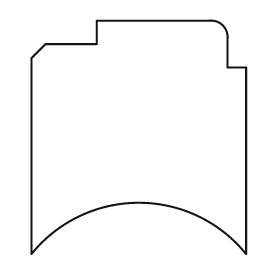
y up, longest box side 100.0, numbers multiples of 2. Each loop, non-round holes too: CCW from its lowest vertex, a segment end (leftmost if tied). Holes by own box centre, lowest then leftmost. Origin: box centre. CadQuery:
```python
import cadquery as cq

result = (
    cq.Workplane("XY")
    .moveTo(-46.0, -50.0)
    .threePointArc((0.0, -28.0), (46.0, -50.0))
    .lineTo(46.0, 30.0)
    .lineTo(38.0, 30.0)
    .lineTo(38.0, 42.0)
    .threePointArc((36.0, 48.0), (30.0, 50.0))
    .lineTo(-18.0, 50.0)
    .lineTo(-18.0, 40.0)
    .lineTo(-40.0, 40.0)
    .lineTo(-46.0, 34.0)
    .close()
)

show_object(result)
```